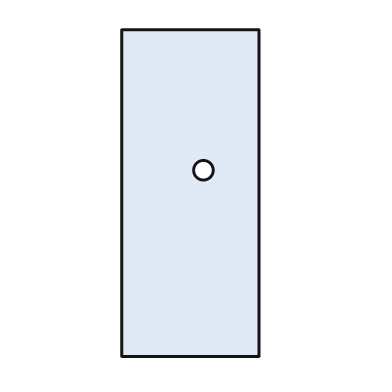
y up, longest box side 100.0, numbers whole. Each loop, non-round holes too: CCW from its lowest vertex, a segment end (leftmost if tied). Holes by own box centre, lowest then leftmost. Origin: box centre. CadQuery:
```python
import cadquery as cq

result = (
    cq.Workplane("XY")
    .moveTo(-21.0, -50.0)
    .lineTo(21.0, -50.0)
    .lineTo(21.0, 50.0)
    .lineTo(-21.0, 50.0)
    .close()
    .moveTo(4.0, 7.0)
    .circle(3.0)
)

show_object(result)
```